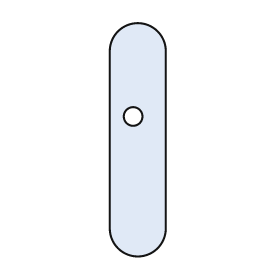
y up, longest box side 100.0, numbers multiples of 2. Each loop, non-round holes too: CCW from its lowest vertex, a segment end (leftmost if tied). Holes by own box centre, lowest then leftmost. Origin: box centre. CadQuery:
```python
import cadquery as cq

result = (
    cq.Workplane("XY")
    .moveTo(-12.0, -38.0)
    .threePointArc((0.0, -50.0), (12.0, -38.0))
    .lineTo(12.0, 38.0)
    .threePointArc((0.0, 50.0), (-12.0, 38.0))
    .close()
    .moveTo(-2.0, 10.0)
    .circle(4.0)
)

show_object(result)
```